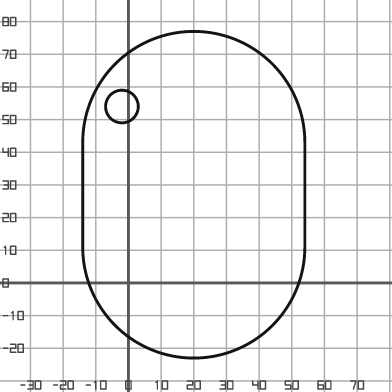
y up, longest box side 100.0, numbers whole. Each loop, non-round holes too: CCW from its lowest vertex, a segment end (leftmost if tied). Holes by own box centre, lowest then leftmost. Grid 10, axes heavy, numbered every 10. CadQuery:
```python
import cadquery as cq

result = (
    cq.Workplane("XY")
    .moveTo(-14.0, 11.0)
    .threePointArc((20.0, -23.0), (54.0, 11.0))
    .lineTo(54.0, 43.0)
    .threePointArc((20.0, 77.0), (-14.0, 43.0))
    .close()
    .moveTo(-2.0, 54.0)
    .circle(5.0)
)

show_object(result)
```